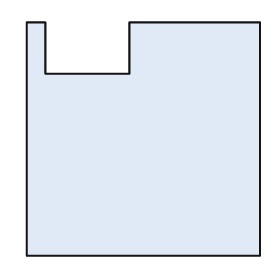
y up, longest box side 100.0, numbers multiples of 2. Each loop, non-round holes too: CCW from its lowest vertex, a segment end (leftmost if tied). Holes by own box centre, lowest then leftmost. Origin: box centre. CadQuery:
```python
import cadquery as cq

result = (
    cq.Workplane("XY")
    .moveTo(-50.0, -50.0)
    .lineTo(50.0, -50.0)
    .lineTo(50.0, 50.0)
    .lineTo(-6.0, 50.0)
    .lineTo(-6.0, 28.0)
    .lineTo(-42.0, 28.0)
    .lineTo(-42.0, 50.0)
    .lineTo(-50.0, 50.0)
    .close()
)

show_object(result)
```